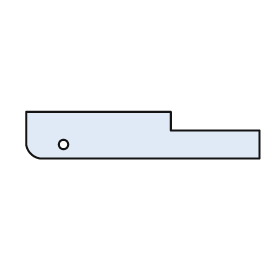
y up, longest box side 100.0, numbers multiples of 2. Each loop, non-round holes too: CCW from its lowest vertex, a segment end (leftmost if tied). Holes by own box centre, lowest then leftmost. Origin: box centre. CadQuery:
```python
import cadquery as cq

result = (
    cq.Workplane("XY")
    .moveTo(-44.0, -10.0)
    .lineTo(50.0, -10.0)
    .lineTo(50.0, 2.0)
    .lineTo(12.0, 2.0)
    .lineTo(12.0, 10.0)
    .lineTo(-50.0, 10.0)
    .lineTo(-50.0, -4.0)
    .threePointArc((-48.0, -8.0), (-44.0, -10.0))
    .close()
    .moveTo(-34.0, -4.0)
    .circle(2.0)
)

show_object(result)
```